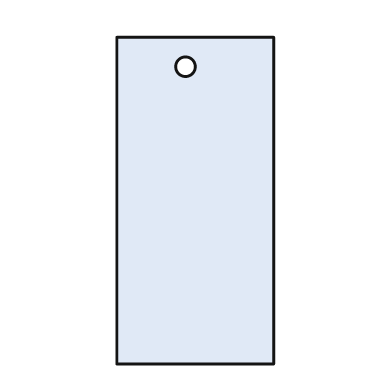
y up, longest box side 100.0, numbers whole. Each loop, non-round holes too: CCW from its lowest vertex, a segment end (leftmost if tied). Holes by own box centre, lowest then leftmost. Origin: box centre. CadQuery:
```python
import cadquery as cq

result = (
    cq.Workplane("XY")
    .moveTo(-24.0, -50.0)
    .lineTo(24.0, -50.0)
    .lineTo(24.0, 50.0)
    .lineTo(-24.0, 50.0)
    .close()
    .moveTo(-3.0, 41.0)
    .circle(3.0)
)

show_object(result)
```